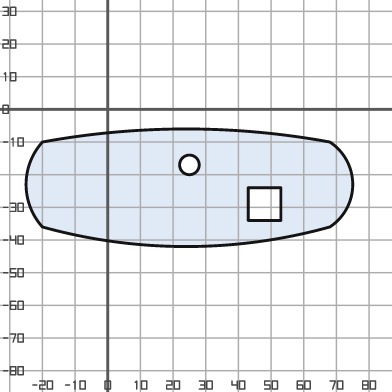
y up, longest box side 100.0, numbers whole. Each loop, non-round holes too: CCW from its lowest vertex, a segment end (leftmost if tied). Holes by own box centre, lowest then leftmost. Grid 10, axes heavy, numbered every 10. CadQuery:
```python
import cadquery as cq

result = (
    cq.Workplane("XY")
    .moveTo(-20.0, -36.0)
    .threePointArc((24.0, -42.0), (68.0, -36.0))
    .threePointArc((75.0, -23.0), (68.0, -10.0))
    .threePointArc((24.0, -6.0), (-20.0, -10.0))
    .threePointArc((-25.0, -23.0), (-20.0, -36.0))
    .close()
    .moveTo(43.0, -34.0)
    .lineTo(53.0, -34.0)
    .lineTo(53.0, -24.0)
    .lineTo(43.0, -24.0)
    .close()
    .moveTo(25.0, -17.0)
    .circle(3.0)
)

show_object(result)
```